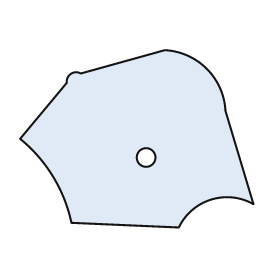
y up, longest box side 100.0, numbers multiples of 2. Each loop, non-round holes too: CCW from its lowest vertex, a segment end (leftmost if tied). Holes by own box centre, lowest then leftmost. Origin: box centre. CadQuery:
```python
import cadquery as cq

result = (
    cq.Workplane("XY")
    .moveTo(18.0, -38.0)
    .threePointArc((32.0, -26.0), (50.0, -28.0))
    .lineTo(38.0, 12.0)
    .threePointArc((30.0, 30.0), (12.0, 38.0))
    .lineTo(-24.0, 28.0)
    .threePointArc((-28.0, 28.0), (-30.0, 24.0))
    .lineTo(-50.0, 0.0)
    .threePointArc((-36.0, -16.0), (-28.0, -36.0))
    .close()
    .moveTo(4.0, -8.0)
    .circle(4.0)
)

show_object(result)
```